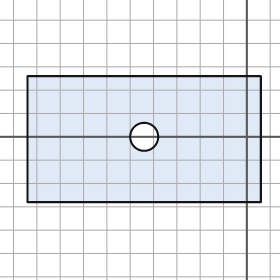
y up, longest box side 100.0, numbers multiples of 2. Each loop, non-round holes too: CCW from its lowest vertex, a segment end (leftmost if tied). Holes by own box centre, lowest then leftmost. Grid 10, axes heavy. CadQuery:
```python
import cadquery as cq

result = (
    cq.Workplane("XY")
    .moveTo(-94.0, -28.0)
    .lineTo(6.0, -28.0)
    .lineTo(6.0, 26.0)
    .lineTo(-94.0, 26.0)
    .close()
    .moveTo(-44.0, 0.0)
    .circle(6.0)
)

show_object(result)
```